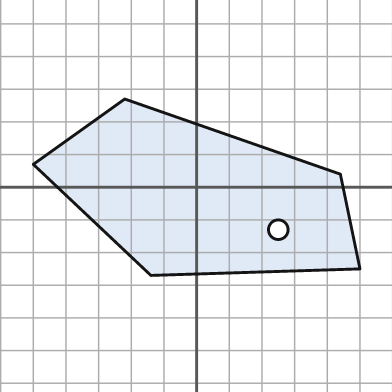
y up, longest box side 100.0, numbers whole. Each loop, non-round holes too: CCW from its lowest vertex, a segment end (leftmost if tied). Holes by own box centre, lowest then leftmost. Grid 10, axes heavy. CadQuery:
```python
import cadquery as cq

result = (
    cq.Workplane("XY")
    .moveTo(-14.0, -27.0)
    .lineTo(50.0, -25.0)
    .lineTo(44.0, 4.0)
    .lineTo(-22.0, 27.0)
    .lineTo(-50.0, 7.0)
    .close()
    .moveTo(25.0, -13.0)
    .circle(3.0)
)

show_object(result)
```